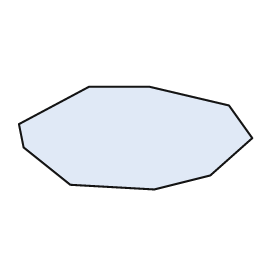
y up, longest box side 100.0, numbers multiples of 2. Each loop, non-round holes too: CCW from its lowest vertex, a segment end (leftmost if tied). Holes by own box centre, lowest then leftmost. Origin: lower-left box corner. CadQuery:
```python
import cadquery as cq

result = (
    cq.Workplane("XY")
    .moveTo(58.0, 0.0)
    .lineTo(82.0, 6.0)
    .lineTo(100.0, 22.0)
    .lineTo(90.0, 36.0)
    .lineTo(56.0, 44.0)
    .lineTo(30.0, 44.0)
    .lineTo(0.0, 28.0)
    .lineTo(2.0, 18.0)
    .lineTo(22.0, 2.0)
    .close()
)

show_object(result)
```